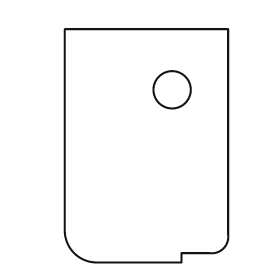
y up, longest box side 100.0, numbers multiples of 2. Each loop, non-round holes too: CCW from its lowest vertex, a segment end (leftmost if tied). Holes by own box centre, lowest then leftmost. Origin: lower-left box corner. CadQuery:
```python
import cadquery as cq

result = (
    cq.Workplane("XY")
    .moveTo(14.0, 0.0)
    .lineTo(50.0, 0.0)
    .lineTo(50.0, 4.0)
    .lineTo(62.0, 4.0)
    .threePointArc((68.0, 6.0), (70.0, 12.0))
    .lineTo(70.0, 100.0)
    .lineTo(0.0, 100.0)
    .lineTo(0.0, 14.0)
    .threePointArc((4.0, 4.0), (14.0, 0.0))
    .close()
    .moveTo(46.0, 74.0)
    .circle(8.0)
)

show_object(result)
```